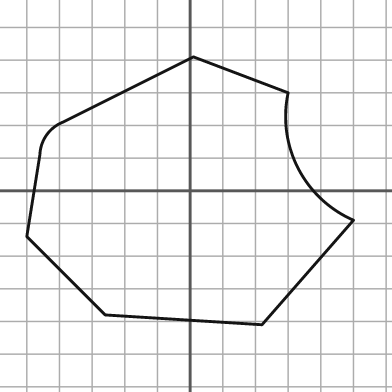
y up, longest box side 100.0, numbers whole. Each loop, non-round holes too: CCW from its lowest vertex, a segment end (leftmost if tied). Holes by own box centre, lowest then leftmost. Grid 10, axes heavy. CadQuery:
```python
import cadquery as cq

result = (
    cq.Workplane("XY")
    .moveTo(22.0, -41.0)
    .lineTo(50.0, -9.0)
    .threePointArc((33.0, 7.0), (30.0, 30.0))
    .lineTo(1.0, 41.0)
    .lineTo(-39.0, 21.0)
    .threePointArc((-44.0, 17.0), (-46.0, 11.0))
    .lineTo(-50.0, -14.0)
    .lineTo(-26.0, -38.0)
    .close()
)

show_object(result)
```